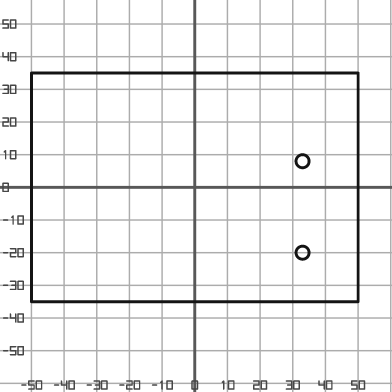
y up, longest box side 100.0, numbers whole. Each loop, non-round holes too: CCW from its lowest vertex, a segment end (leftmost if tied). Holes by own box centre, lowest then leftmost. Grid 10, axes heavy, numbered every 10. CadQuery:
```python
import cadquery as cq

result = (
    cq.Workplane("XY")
    .moveTo(-50.0, -35.0)
    .lineTo(50.0, -35.0)
    .lineTo(50.0, 35.0)
    .lineTo(-50.0, 35.0)
    .close()
    .moveTo(33.0, -20.0)
    .circle(2.0)
    .moveTo(33.0, 8.0)
    .circle(2.0)
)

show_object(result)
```